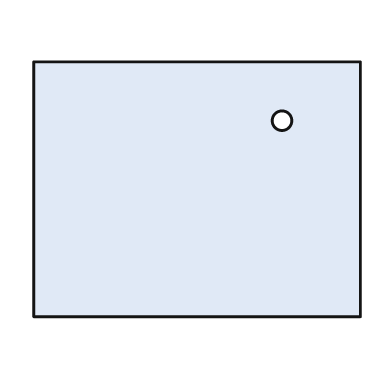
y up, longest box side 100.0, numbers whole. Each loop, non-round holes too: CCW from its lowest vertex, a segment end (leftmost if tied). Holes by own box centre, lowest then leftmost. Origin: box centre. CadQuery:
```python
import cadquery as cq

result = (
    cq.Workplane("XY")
    .moveTo(-50.0, -39.0)
    .lineTo(50.0, -39.0)
    .lineTo(50.0, 39.0)
    .lineTo(-50.0, 39.0)
    .close()
    .moveTo(26.0, 21.0)
    .circle(3.0)
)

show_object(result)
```